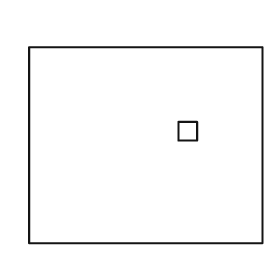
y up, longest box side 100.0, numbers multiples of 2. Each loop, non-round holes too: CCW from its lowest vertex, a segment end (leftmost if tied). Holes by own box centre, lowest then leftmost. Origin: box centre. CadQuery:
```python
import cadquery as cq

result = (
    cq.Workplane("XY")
    .moveTo(-50.0, -42.0)
    .lineTo(50.0, -42.0)
    .lineTo(50.0, 42.0)
    .lineTo(-50.0, 42.0)
    .close()
    .moveTo(14.0, 2.0)
    .lineTo(22.0, 2.0)
    .lineTo(22.0, 10.0)
    .lineTo(14.0, 10.0)
    .close()
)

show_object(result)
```